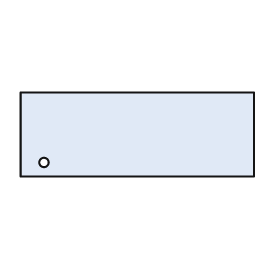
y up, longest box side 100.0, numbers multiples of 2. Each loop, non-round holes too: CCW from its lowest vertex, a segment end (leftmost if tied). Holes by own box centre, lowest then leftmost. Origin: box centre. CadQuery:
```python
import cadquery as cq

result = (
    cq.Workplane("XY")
    .moveTo(-50.0, -18.0)
    .lineTo(50.0, -18.0)
    .lineTo(50.0, 18.0)
    .lineTo(-50.0, 18.0)
    .close()
    .moveTo(-40.0, -12.0)
    .circle(2.0)
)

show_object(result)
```